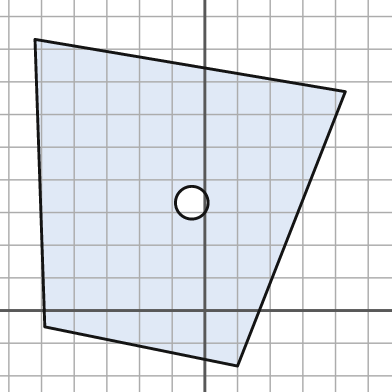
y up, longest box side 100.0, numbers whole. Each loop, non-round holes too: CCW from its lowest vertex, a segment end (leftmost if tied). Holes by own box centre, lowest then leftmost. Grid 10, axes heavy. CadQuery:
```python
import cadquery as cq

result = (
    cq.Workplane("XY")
    .moveTo(10.0, -17.0)
    .lineTo(43.0, 67.0)
    .lineTo(-52.0, 83.0)
    .lineTo(-49.0, -5.0)
    .close()
    .moveTo(-4.0, 33.0)
    .circle(5.0)
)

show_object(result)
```